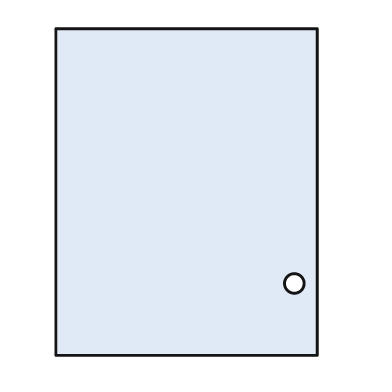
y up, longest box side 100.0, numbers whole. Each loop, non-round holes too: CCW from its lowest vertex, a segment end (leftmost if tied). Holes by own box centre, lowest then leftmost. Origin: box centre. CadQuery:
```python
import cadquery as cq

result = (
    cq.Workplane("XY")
    .moveTo(-40.0, -50.0)
    .lineTo(40.0, -50.0)
    .lineTo(40.0, 50.0)
    .lineTo(-40.0, 50.0)
    .close()
    .moveTo(33.0, -28.0)
    .circle(3.0)
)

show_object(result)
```